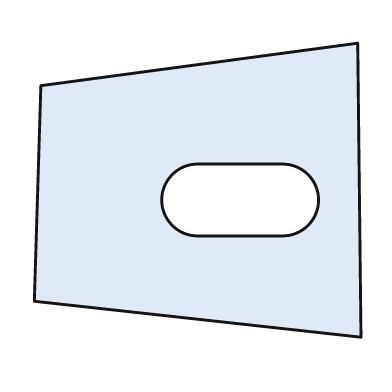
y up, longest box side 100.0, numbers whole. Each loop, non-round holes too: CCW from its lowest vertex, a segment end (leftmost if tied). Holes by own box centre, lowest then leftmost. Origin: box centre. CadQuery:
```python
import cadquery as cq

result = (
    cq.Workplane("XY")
    .moveTo(50.0, -45.0)
    .lineTo(49.0, 45.0)
    .lineTo(-48.0, 32.0)
    .lineTo(-50.0, -34.0)
    .close()
    .moveTo(0.0, -14.0)
    .lineTo(26.0, -14.0)
    .threePointArc((37.0, -3.0), (26.0, 8.0))
    .lineTo(0.0, 8.0)
    .threePointArc((-11.0, -3.0), (0.0, -14.0))
    .close()
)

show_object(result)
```